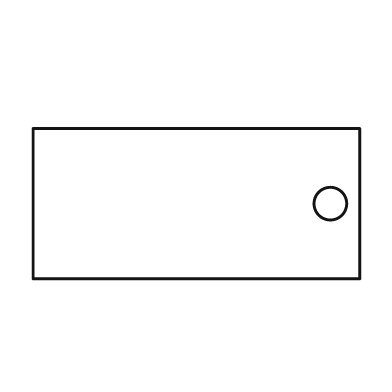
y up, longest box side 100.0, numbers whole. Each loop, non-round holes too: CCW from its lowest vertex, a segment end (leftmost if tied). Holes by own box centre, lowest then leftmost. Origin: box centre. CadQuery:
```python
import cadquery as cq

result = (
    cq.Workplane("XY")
    .moveTo(-50.0, -23.0)
    .lineTo(50.0, -23.0)
    .lineTo(50.0, 23.0)
    .lineTo(-50.0, 23.0)
    .close()
    .moveTo(41.0, 0.0)
    .circle(5.0)
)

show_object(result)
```